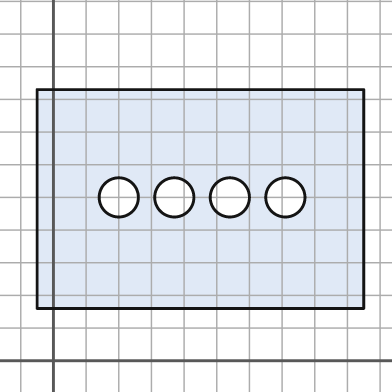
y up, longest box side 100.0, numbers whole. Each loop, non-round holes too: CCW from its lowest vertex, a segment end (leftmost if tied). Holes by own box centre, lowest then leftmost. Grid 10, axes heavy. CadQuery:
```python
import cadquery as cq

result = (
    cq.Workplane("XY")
    .moveTo(-5.0, 16.0)
    .lineTo(95.0, 16.0)
    .lineTo(95.0, 83.0)
    .lineTo(-5.0, 83.0)
    .close()
    .moveTo(20.0, 50.0)
    .circle(6.0)
    .moveTo(37.0, 50.0)
    .circle(6.0)
    .moveTo(54.0, 50.0)
    .circle(6.0)
    .moveTo(71.0, 50.0)
    .circle(6.0)
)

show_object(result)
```